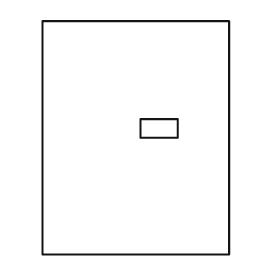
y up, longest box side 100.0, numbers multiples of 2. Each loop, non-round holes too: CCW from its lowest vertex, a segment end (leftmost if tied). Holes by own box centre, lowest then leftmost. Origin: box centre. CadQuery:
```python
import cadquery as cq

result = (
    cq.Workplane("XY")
    .moveTo(-40.0, -50.0)
    .lineTo(40.0, -50.0)
    .lineTo(40.0, 50.0)
    .lineTo(-40.0, 50.0)
    .close()
    .moveTo(2.0, 0.0)
    .lineTo(18.0, 0.0)
    .lineTo(18.0, 8.0)
    .lineTo(2.0, 8.0)
    .close()
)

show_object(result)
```